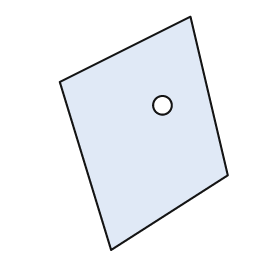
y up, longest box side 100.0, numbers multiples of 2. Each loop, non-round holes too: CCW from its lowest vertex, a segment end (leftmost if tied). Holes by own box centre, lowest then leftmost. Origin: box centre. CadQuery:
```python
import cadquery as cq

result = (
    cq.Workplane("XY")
    .moveTo(-14.0, -50.0)
    .lineTo(36.0, -18.0)
    .lineTo(20.0, 50.0)
    .lineTo(-36.0, 22.0)
    .close()
    .moveTo(8.0, 12.0)
    .circle(4.0)
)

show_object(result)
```